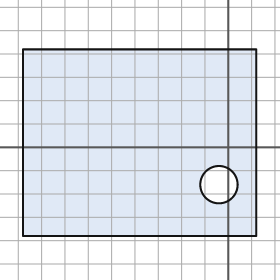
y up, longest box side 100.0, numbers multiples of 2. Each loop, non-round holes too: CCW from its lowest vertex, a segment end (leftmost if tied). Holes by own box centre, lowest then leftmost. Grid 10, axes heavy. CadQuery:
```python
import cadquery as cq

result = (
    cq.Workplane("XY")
    .moveTo(-88.0, -38.0)
    .lineTo(12.0, -38.0)
    .lineTo(12.0, 42.0)
    .lineTo(-88.0, 42.0)
    .close()
    .moveTo(-4.0, -16.0)
    .circle(8.0)
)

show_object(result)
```